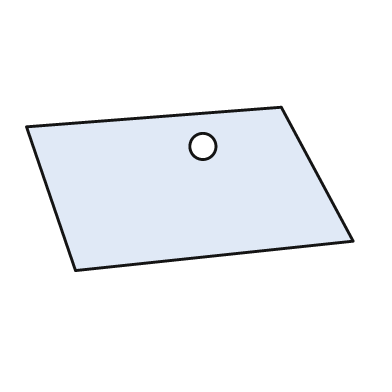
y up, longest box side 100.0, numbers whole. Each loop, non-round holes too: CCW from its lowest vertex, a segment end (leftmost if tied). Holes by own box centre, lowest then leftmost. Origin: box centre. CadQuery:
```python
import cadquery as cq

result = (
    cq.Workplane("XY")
    .moveTo(-35.0, -25.0)
    .lineTo(50.0, -16.0)
    .lineTo(28.0, 25.0)
    .lineTo(-50.0, 19.0)
    .close()
    .moveTo(4.0, 13.0)
    .circle(4.0)
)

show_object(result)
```